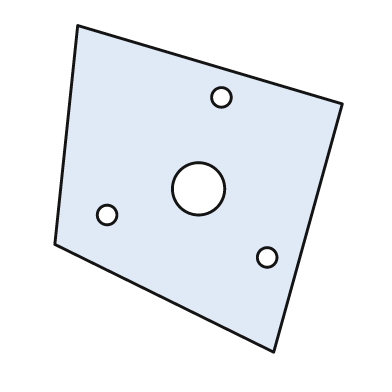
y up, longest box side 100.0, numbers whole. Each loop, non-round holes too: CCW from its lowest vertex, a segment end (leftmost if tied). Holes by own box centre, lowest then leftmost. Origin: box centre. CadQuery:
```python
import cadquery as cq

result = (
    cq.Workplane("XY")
    .moveTo(23.0, -50.0)
    .lineTo(44.0, 26.0)
    .lineTo(-37.0, 50.0)
    .lineTo(-44.0, -17.0)
    .close()
    .moveTo(21.0, -21.0)
    .circle(3.0)
    .moveTo(-28.0, -8.0)
    .circle(3.0)
    .moveTo(0.0, 0.0)
    .circle(8.0)
    .moveTo(7.0, 28.0)
    .circle(3.0)
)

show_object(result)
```